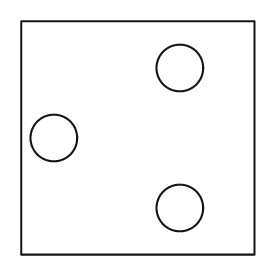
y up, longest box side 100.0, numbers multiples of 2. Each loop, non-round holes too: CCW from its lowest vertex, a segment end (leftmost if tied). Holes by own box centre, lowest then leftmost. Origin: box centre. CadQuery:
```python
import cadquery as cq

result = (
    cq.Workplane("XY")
    .moveTo(-50.0, -50.0)
    .lineTo(50.0, -50.0)
    .lineTo(50.0, 50.0)
    .lineTo(-50.0, 50.0)
    .close()
    .moveTo(18.0, -30.0)
    .circle(10.0)
    .moveTo(-36.0, 0.0)
    .circle(10.0)
    .moveTo(18.0, 30.0)
    .circle(10.0)
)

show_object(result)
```